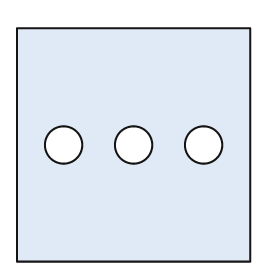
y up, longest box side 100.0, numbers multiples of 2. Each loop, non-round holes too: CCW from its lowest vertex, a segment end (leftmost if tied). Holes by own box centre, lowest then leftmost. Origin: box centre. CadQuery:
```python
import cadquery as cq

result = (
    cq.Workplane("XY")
    .moveTo(-50.0, -50.0)
    .lineTo(50.0, -50.0)
    .lineTo(50.0, 50.0)
    .lineTo(-50.0, 50.0)
    .close()
    .moveTo(-30.0, 0.0)
    .circle(8.0)
    .moveTo(0.0, 0.0)
    .circle(8.0)
    .moveTo(30.0, 0.0)
    .circle(8.0)
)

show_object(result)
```